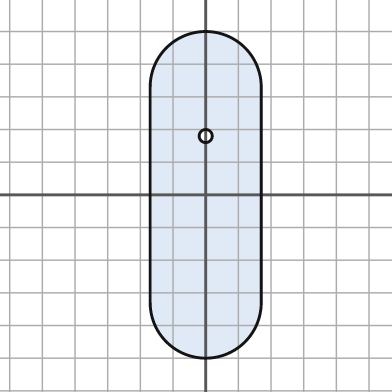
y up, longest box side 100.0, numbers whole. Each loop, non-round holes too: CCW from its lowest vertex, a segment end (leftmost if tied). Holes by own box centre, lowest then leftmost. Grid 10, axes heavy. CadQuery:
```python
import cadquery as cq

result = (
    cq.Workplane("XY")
    .moveTo(-17.0, -33.0)
    .threePointArc((0.0, -50.0), (17.0, -33.0))
    .lineTo(17.0, 33.0)
    .threePointArc((0.0, 50.0), (-17.0, 33.0))
    .close()
    .moveTo(0.0, 18.0)
    .circle(2.0)
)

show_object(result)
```